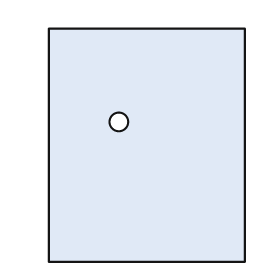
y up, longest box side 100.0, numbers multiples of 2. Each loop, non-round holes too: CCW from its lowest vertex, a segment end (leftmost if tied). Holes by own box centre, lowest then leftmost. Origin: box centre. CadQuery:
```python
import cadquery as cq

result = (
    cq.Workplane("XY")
    .moveTo(-42.0, -50.0)
    .lineTo(42.0, -50.0)
    .lineTo(42.0, 50.0)
    .lineTo(-42.0, 50.0)
    .close()
    .moveTo(-12.0, 10.0)
    .circle(4.0)
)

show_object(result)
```